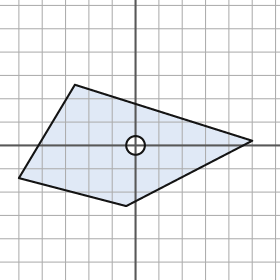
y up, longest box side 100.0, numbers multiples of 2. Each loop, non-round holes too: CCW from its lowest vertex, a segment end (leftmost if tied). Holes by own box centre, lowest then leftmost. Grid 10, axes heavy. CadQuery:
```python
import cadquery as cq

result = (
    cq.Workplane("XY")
    .moveTo(-4.0, -26.0)
    .lineTo(50.0, 2.0)
    .lineTo(-26.0, 26.0)
    .lineTo(-50.0, -14.0)
    .close()
    .moveTo(0.0, 0.0)
    .circle(4.0)
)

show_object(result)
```